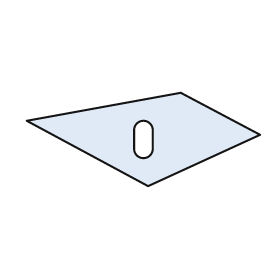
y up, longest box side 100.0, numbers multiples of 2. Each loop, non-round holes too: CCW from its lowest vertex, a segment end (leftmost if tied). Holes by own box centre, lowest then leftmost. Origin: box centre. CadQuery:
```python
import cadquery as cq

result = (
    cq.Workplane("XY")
    .moveTo(2.0, -20.0)
    .lineTo(50.0, 2.0)
    .lineTo(16.0, 20.0)
    .lineTo(-50.0, 8.0)
    .close()
    .moveTo(-4.0, -4.0)
    .threePointArc((0.0, -8.0), (4.0, -4.0))
    .lineTo(4.0, 4.0)
    .threePointArc((0.0, 8.0), (-4.0, 4.0))
    .close()
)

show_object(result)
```